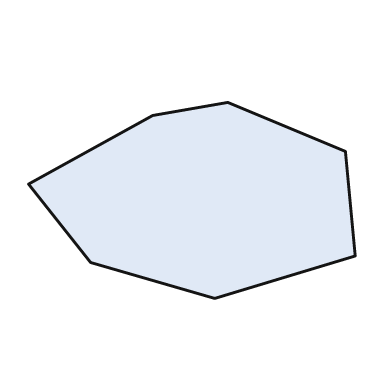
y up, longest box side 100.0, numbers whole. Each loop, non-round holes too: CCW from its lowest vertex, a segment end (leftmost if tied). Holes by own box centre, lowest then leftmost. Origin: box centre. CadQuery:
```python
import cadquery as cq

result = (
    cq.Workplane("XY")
    .moveTo(7.0, -30.0)
    .lineTo(50.0, -17.0)
    .lineTo(47.0, 15.0)
    .lineTo(11.0, 30.0)
    .lineTo(-12.0, 26.0)
    .lineTo(-50.0, 5.0)
    .lineTo(-31.0, -19.0)
    .close()
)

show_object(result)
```